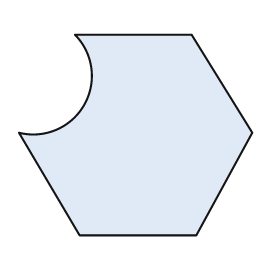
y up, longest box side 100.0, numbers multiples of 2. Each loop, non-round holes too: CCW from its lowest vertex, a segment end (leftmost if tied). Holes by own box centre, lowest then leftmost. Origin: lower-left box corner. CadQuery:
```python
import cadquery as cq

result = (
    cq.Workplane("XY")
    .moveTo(26.0, 0.0)
    .lineTo(76.0, 0.0)
    .lineTo(100.0, 44.0)
    .lineTo(74.0, 86.0)
    .lineTo(24.0, 86.0)
    .threePointArc((28.0, 56.0), (0.0, 44.0))
    .close()
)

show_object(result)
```